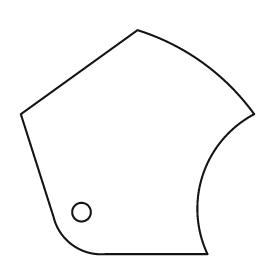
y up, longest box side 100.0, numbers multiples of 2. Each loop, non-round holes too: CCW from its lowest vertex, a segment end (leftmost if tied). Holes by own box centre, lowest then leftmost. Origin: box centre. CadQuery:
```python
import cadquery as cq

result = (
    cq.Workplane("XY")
    .moveTo(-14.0, -48.0)
    .lineTo(30.0, -48.0)
    .threePointArc((28.0, -14.0), (50.0, 12.0))
    .threePointArc((28.0, 34.0), (0.0, 48.0))
    .lineTo(-50.0, 12.0)
    .lineTo(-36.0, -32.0)
    .threePointArc((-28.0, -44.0), (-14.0, -48.0))
    .close()
    .moveTo(-24.0, -30.0)
    .circle(4.0)
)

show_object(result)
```